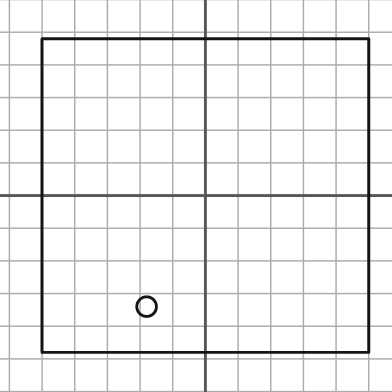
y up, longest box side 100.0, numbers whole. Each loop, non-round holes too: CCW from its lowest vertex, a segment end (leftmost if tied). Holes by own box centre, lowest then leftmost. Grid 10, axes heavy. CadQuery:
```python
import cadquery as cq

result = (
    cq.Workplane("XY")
    .moveTo(-50.0, -48.0)
    .lineTo(50.0, -48.0)
    .lineTo(50.0, 48.0)
    .lineTo(-50.0, 48.0)
    .close()
    .moveTo(-18.0, -34.0)
    .circle(3.0)
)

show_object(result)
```